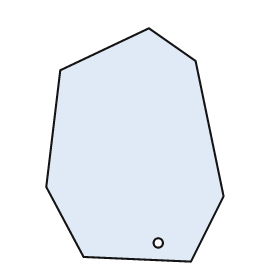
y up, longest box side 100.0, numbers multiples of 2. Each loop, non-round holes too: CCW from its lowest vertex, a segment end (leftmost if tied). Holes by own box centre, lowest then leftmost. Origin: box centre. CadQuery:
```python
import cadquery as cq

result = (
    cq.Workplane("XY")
    .moveTo(24.0, -50.0)
    .lineTo(38.0, -22.0)
    .lineTo(26.0, 36.0)
    .lineTo(6.0, 50.0)
    .lineTo(-32.0, 32.0)
    .lineTo(-38.0, -18.0)
    .lineTo(-22.0, -48.0)
    .close()
    .moveTo(10.0, -42.0)
    .circle(2.0)
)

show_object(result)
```